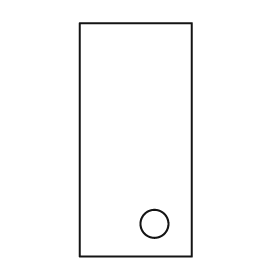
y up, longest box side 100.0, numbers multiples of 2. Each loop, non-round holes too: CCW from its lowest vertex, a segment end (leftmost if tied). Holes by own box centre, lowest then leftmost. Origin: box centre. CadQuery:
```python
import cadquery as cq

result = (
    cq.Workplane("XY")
    .moveTo(-24.0, -50.0)
    .lineTo(24.0, -50.0)
    .lineTo(24.0, 50.0)
    .lineTo(-24.0, 50.0)
    .close()
    .moveTo(8.0, -36.0)
    .circle(6.0)
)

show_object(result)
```